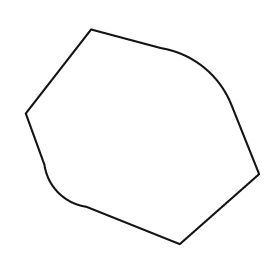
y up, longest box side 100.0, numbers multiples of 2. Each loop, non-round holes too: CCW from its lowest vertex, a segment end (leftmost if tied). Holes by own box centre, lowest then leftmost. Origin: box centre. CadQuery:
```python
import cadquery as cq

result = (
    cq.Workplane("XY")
    .moveTo(16.0, -46.0)
    .lineTo(50.0, -16.0)
    .lineTo(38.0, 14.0)
    .threePointArc((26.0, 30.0), (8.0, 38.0))
    .lineTo(-22.0, 46.0)
    .lineTo(-50.0, 10.0)
    .lineTo(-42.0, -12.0)
    .threePointArc((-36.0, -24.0), (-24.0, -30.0))
    .close()
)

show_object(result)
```